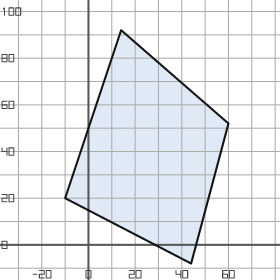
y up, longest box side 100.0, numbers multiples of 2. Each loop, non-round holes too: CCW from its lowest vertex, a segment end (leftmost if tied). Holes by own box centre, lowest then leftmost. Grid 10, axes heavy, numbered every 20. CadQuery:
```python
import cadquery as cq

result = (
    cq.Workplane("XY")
    .moveTo(44.0, -8.0)
    .lineTo(60.0, 52.0)
    .lineTo(14.0, 92.0)
    .lineTo(-10.0, 20.0)
    .close()
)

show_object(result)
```